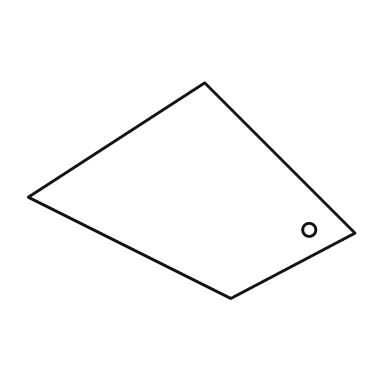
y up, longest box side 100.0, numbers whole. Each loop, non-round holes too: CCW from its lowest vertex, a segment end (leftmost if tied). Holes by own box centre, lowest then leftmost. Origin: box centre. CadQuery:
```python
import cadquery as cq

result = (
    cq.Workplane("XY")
    .moveTo(12.0, -33.0)
    .lineTo(50.0, -13.0)
    .lineTo(4.0, 33.0)
    .lineTo(-50.0, -2.0)
    .close()
    .moveTo(36.0, -12.0)
    .circle(2.0)
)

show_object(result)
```